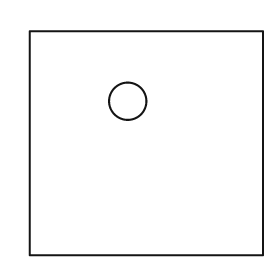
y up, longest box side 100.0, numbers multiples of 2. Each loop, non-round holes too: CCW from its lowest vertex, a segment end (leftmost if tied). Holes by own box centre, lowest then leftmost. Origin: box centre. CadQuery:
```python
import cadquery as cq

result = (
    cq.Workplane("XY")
    .moveTo(-50.0, -48.0)
    .lineTo(50.0, -48.0)
    .lineTo(50.0, 48.0)
    .lineTo(-50.0, 48.0)
    .close()
    .moveTo(-8.0, 18.0)
    .circle(8.0)
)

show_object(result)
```